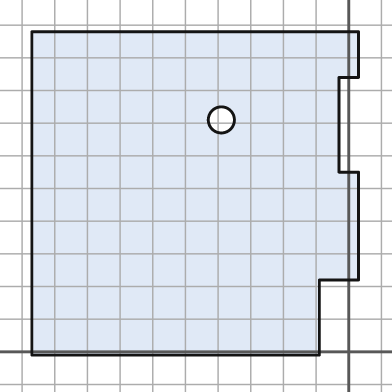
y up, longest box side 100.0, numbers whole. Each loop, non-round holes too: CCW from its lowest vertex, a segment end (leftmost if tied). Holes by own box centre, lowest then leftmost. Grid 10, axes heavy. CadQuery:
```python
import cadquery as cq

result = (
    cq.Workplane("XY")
    .moveTo(-97.0, -1.0)
    .lineTo(-9.0, -1.0)
    .lineTo(-9.0, 22.0)
    .lineTo(3.0, 22.0)
    .lineTo(3.0, 55.0)
    .lineTo(-3.0, 55.0)
    .lineTo(-3.0, 84.0)
    .lineTo(3.0, 84.0)
    .lineTo(3.0, 98.0)
    .lineTo(-97.0, 98.0)
    .close()
    .moveTo(-39.0, 71.0)
    .circle(4.0)
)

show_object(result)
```